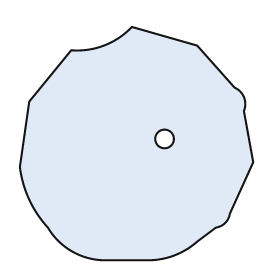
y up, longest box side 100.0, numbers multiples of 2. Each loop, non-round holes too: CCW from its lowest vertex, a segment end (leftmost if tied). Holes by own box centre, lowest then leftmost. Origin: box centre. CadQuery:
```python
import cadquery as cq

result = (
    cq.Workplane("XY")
    .moveTo(-14.0, -50.0)
    .lineTo(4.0, -50.0)
    .threePointArc((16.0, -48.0), (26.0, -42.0))
    .lineTo(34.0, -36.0)
    .threePointArc((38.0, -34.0), (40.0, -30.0))
    .lineTo(50.0, -8.0)
    .lineTo(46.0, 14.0)
    .threePointArc((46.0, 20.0), (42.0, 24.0))
    .lineTo(26.0, 42.0)
    .lineTo(-2.0, 50.0)
    .threePointArc((-14.0, 42.0), (-28.0, 40.0))
    .lineTo(-46.0, 18.0)
    .lineTo(-50.0, -10.0)
    .threePointArc((-46.0, -24.0), (-38.0, -36.0))
    .threePointArc((-28.0, -46.0), (-14.0, -50.0))
    .close()
    .moveTo(12.0, 2.0)
    .circle(4.0)
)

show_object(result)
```